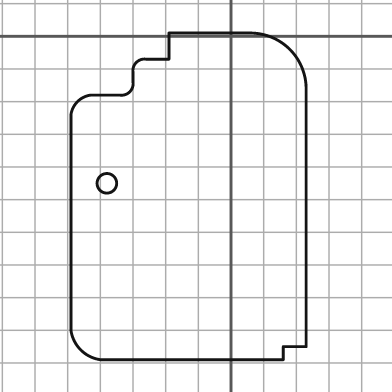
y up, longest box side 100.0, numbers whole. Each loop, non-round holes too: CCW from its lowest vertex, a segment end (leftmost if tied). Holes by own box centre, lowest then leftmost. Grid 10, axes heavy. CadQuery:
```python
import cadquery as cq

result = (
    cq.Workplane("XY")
    .moveTo(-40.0, -99.0)
    .lineTo(16.0, -99.0)
    .lineTo(16.0, -95.0)
    .lineTo(23.0, -95.0)
    .lineTo(23.0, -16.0)
    .threePointArc((18.0, -4.0), (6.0, 1.0))
    .lineTo(-19.0, 1.0)
    .lineTo(-19.0, -7.0)
    .lineTo(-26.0, -7.0)
    .threePointArc((-29.0, -8.0), (-30.0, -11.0))
    .lineTo(-30.0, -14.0)
    .threePointArc((-31.0, -17.0), (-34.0, -18.0))
    .lineTo(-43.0, -18.0)
    .threePointArc((-47.0, -20.0), (-49.0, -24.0))
    .lineTo(-49.0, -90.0)
    .threePointArc((-46.0, -96.0), (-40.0, -99.0))
    .close()
    .moveTo(-38.0, -45.0)
    .circle(3.0)
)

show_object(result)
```